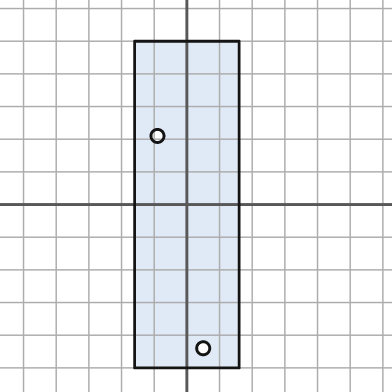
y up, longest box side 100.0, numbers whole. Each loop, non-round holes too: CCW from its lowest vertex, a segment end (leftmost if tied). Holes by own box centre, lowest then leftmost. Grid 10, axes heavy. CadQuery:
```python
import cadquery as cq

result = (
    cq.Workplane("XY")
    .moveTo(-16.0, -50.0)
    .lineTo(16.0, -50.0)
    .lineTo(16.0, 50.0)
    .lineTo(-16.0, 50.0)
    .close()
    .moveTo(5.0, -44.0)
    .circle(2.0)
    .moveTo(-9.0, 21.0)
    .circle(2.0)
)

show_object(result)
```